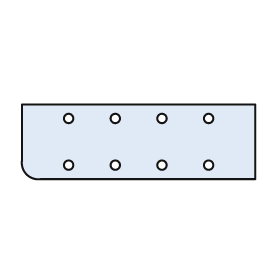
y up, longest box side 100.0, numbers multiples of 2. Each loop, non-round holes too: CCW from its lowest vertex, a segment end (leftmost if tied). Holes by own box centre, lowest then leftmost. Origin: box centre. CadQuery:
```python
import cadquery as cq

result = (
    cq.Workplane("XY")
    .moveTo(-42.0, -16.0)
    .lineTo(50.0, -16.0)
    .lineTo(50.0, 16.0)
    .lineTo(-50.0, 16.0)
    .lineTo(-50.0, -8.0)
    .threePointArc((-48.0, -14.0), (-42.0, -16.0))
    .close()
    .moveTo(-30.0, -10.0)
    .circle(2.0)
    .moveTo(-10.0, -10.0)
    .circle(2.0)
    .moveTo(10.0, -10.0)
    .circle(2.0)
    .moveTo(30.0, -10.0)
    .circle(2.0)
    .moveTo(-30.0, 10.0)
    .circle(2.0)
    .moveTo(-10.0, 10.0)
    .circle(2.0)
    .moveTo(10.0, 10.0)
    .circle(2.0)
    .moveTo(30.0, 10.0)
    .circle(2.0)
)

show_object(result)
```